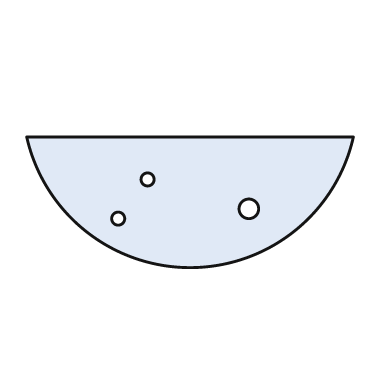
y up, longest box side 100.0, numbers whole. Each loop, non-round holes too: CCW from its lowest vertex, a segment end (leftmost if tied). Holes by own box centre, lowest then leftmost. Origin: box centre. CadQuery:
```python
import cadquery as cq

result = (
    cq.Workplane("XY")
    .moveTo(-50.0, 20.0)
    .threePointArc((0.0, -20.0), (50.0, 20.0))
    .close()
    .moveTo(-22.0, -5.0)
    .circle(2.0)
    .moveTo(18.0, -2.0)
    .circle(3.0)
    .moveTo(-13.0, 7.0)
    .circle(2.0)
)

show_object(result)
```